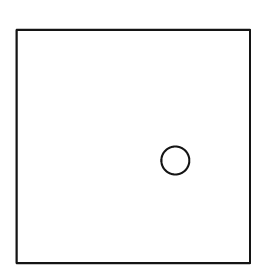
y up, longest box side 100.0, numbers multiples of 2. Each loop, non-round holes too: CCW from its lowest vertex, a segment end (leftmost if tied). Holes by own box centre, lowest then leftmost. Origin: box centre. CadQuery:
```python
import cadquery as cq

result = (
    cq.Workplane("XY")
    .moveTo(-50.0, -50.0)
    .lineTo(50.0, -50.0)
    .lineTo(50.0, 50.0)
    .lineTo(-50.0, 50.0)
    .close()
    .moveTo(18.0, -6.0)
    .circle(6.0)
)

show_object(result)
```